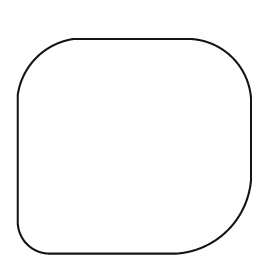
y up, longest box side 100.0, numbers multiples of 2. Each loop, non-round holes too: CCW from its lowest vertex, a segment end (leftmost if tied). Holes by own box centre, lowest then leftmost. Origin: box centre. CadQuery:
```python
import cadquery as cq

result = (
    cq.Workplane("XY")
    .moveTo(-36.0, -46.0)
    .lineTo(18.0, -46.0)
    .threePointArc((40.0, -36.0), (50.0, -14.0))
    .lineTo(50.0, 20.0)
    .threePointArc((42.0, 38.0), (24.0, 46.0))
    .lineTo(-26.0, 46.0)
    .threePointArc((-42.0, 38.0), (-50.0, 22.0))
    .lineTo(-50.0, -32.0)
    .threePointArc((-46.0, -42.0), (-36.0, -46.0))
    .close()
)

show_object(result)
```